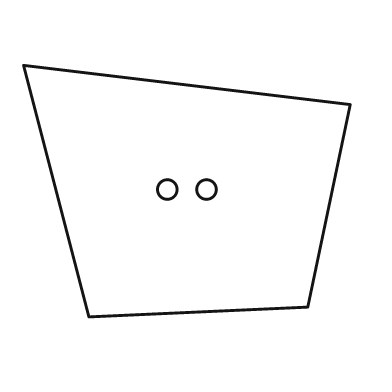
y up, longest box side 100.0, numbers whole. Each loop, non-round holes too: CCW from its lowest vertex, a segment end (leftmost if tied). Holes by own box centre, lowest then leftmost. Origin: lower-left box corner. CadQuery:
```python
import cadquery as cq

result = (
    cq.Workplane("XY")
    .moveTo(20.0, 0.0)
    .lineTo(87.0, 3.0)
    .lineTo(100.0, 65.0)
    .lineTo(0.0, 77.0)
    .close()
    .moveTo(44.0, 39.0)
    .circle(3.0)
    .moveTo(56.0, 39.0)
    .circle(3.0)
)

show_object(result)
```